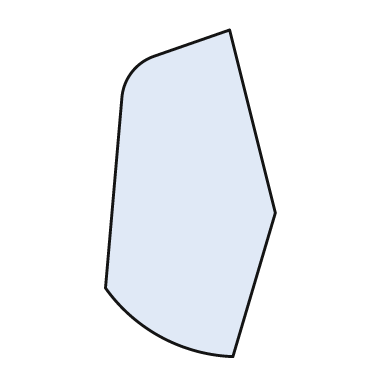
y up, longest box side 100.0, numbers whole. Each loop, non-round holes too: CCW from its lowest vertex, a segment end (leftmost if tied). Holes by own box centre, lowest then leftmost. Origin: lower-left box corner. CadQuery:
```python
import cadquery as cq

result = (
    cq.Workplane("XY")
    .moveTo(39.0, 0.0)
    .lineTo(52.0, 44.0)
    .lineTo(38.0, 100.0)
    .lineTo(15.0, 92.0)
    .threePointArc((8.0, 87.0), (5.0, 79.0))
    .lineTo(0.0, 21.0)
    .threePointArc((17.0, 6.0), (39.0, 0.0))
    .close()
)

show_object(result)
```